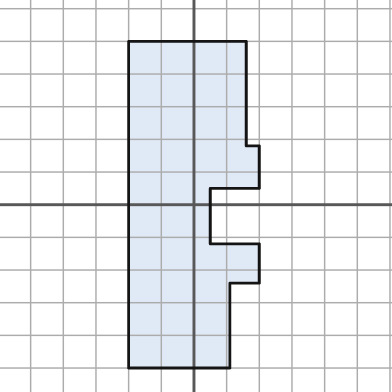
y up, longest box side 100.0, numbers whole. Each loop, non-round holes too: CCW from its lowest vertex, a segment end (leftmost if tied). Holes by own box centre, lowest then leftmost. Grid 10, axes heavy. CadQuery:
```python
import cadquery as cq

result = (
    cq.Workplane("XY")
    .moveTo(-20.0, -50.0)
    .lineTo(11.0, -50.0)
    .lineTo(11.0, -24.0)
    .lineTo(20.0, -24.0)
    .lineTo(20.0, -12.0)
    .lineTo(5.0, -12.0)
    .lineTo(5.0, 5.0)
    .lineTo(20.0, 5.0)
    .lineTo(20.0, 18.0)
    .lineTo(16.0, 18.0)
    .lineTo(16.0, 50.0)
    .lineTo(-20.0, 50.0)
    .close()
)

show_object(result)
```